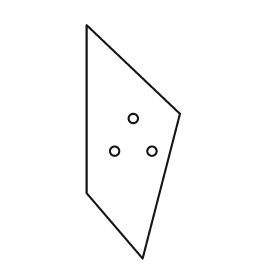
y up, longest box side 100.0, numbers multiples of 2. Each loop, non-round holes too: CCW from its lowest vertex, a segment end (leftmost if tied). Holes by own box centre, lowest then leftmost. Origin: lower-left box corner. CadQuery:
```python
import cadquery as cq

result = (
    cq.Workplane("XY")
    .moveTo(24.0, 0.0)
    .lineTo(40.0, 62.0)
    .lineTo(0.0, 100.0)
    .lineTo(0.0, 28.0)
    .close()
    .moveTo(12.0, 46.0)
    .circle(2.0)
    .moveTo(28.0, 46.0)
    .circle(2.0)
    .moveTo(20.0, 60.0)
    .circle(2.0)
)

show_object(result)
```